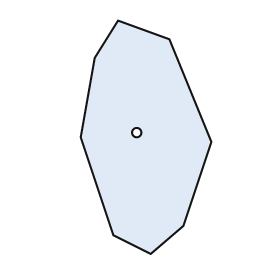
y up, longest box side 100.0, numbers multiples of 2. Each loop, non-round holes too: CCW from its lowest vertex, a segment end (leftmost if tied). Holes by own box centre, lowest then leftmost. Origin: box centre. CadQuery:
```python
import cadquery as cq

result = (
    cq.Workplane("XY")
    .moveTo(2.0, -50.0)
    .lineTo(16.0, -38.0)
    .lineTo(28.0, -2.0)
    .lineTo(10.0, 42.0)
    .lineTo(-12.0, 50.0)
    .lineTo(-22.0, 34.0)
    .lineTo(-28.0, 0.0)
    .lineTo(-14.0, -42.0)
    .close()
    .moveTo(-4.0, 2.0)
    .circle(2.0)
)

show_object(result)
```